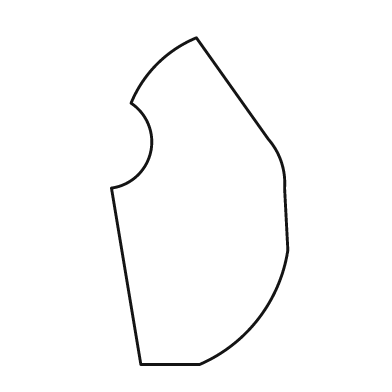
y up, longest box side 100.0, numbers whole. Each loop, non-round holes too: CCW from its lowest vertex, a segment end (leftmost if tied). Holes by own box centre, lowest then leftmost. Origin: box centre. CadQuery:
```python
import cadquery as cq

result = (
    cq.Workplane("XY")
    .moveTo(-18.0, -50.0)
    .lineTo(0.0, -50.0)
    .threePointArc((18.0, -36.0), (27.0, -15.0))
    .lineTo(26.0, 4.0)
    .threePointArc((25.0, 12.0), (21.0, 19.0))
    .lineTo(-1.0, 50.0)
    .threePointArc((-13.0, 42.0), (-21.0, 30.0))
    .threePointArc((-15.0, 15.0), (-27.0, 4.0))
    .close()
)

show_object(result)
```